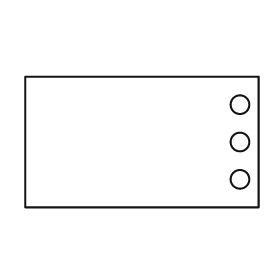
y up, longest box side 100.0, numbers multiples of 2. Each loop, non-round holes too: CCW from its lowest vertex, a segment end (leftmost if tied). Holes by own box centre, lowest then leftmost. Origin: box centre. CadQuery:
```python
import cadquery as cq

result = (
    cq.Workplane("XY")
    .moveTo(-50.0, -28.0)
    .lineTo(50.0, -28.0)
    .lineTo(50.0, 28.0)
    .lineTo(-50.0, 28.0)
    .close()
    .moveTo(42.0, -16.0)
    .circle(4.0)
    .moveTo(42.0, 0.0)
    .circle(4.0)
    .moveTo(42.0, 16.0)
    .circle(4.0)
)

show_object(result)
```